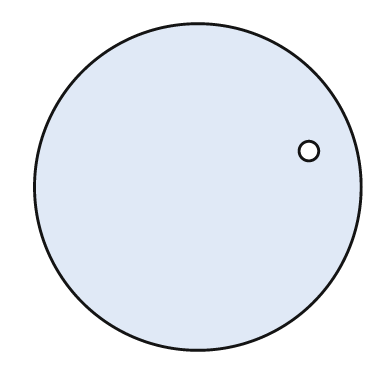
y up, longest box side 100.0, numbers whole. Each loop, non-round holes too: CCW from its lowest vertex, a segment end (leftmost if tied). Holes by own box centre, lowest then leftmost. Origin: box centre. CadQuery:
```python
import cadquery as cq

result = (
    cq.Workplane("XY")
    .moveTo(0.0, 0.0)
    .circle(50.0)
    .moveTo(34.0, 11.0)
    .circle(3.0)
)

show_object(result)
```